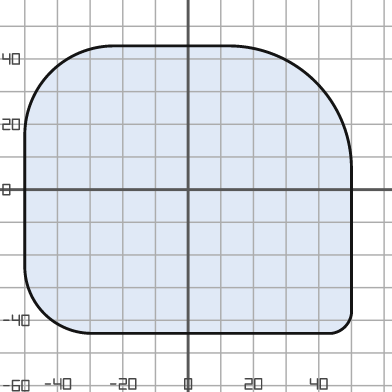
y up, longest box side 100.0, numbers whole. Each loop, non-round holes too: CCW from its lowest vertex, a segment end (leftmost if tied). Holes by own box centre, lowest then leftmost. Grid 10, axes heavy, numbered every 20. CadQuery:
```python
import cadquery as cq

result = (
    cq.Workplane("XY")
    .moveTo(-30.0, -44.0)
    .lineTo(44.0, -44.0)
    .threePointArc((48.0, -42.0), (50.0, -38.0))
    .lineTo(50.0, 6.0)
    .threePointArc((39.0, 33.0), (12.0, 44.0))
    .lineTo(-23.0, 44.0)
    .threePointArc((-42.0, 36.0), (-50.0, 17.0))
    .lineTo(-50.0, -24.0)
    .threePointArc((-44.0, -38.0), (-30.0, -44.0))
    .close()
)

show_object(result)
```